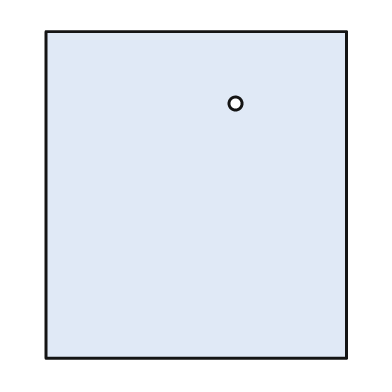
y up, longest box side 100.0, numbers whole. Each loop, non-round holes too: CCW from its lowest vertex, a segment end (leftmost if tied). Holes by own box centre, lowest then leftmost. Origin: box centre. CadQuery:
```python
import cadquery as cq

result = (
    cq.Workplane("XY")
    .moveTo(-46.0, -50.0)
    .lineTo(46.0, -50.0)
    .lineTo(46.0, 50.0)
    .lineTo(-46.0, 50.0)
    .close()
    .moveTo(12.0, 28.0)
    .circle(2.0)
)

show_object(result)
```